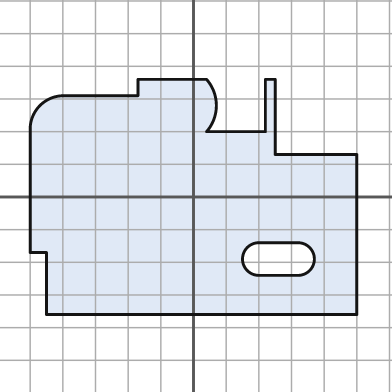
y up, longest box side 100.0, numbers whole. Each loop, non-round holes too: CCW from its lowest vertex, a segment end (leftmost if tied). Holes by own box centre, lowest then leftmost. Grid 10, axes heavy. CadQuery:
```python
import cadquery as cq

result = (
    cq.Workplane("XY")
    .moveTo(-45.0, -36.0)
    .lineTo(50.0, -36.0)
    .lineTo(50.0, 13.0)
    .lineTo(25.0, 13.0)
    .lineTo(25.0, 36.0)
    .lineTo(22.0, 36.0)
    .lineTo(22.0, 20.0)
    .lineTo(4.0, 20.0)
    .threePointArc((7.0, 28.0), (4.0, 36.0))
    .lineTo(-17.0, 36.0)
    .lineTo(-17.0, 31.0)
    .lineTo(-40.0, 31.0)
    .threePointArc((-47.0, 28.0), (-50.0, 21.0))
    .lineTo(-50.0, -17.0)
    .lineTo(-45.0, -17.0)
    .close()
    .moveTo(20.0, -24.0)
    .lineTo(32.0, -24.0)
    .threePointArc((37.0, -19.0), (32.0, -14.0))
    .lineTo(20.0, -14.0)
    .threePointArc((15.0, -19.0), (20.0, -24.0))
    .close()
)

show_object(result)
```